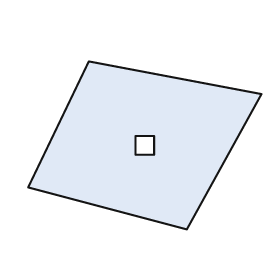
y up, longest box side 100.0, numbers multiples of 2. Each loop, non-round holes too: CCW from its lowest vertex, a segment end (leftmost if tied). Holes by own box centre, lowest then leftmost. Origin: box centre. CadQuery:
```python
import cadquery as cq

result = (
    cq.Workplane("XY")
    .moveTo(18.0, -36.0)
    .lineTo(50.0, 22.0)
    .lineTo(-24.0, 36.0)
    .lineTo(-50.0, -18.0)
    .close()
    .moveTo(-4.0, -4.0)
    .lineTo(4.0, -4.0)
    .lineTo(4.0, 4.0)
    .lineTo(-4.0, 4.0)
    .close()
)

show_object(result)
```